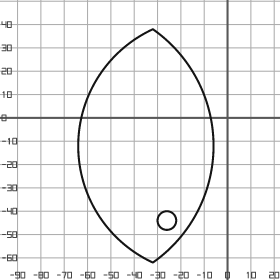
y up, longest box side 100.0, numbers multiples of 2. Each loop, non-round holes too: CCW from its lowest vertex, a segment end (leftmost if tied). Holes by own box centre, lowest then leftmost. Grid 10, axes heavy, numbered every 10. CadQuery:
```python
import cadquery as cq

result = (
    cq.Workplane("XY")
    .moveTo(-32.0, -62.0)
    .threePointArc((-6.0, -12.0), (-32.0, 38.0))
    .threePointArc((-64.0, -12.0), (-32.0, -62.0))
    .close()
    .moveTo(-26.0, -44.0)
    .circle(4.0)
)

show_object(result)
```